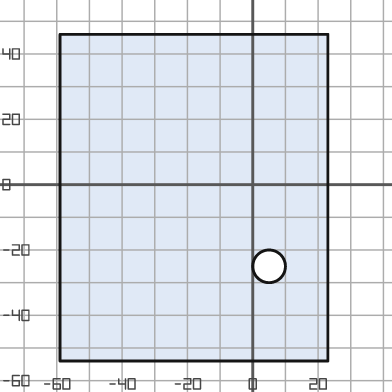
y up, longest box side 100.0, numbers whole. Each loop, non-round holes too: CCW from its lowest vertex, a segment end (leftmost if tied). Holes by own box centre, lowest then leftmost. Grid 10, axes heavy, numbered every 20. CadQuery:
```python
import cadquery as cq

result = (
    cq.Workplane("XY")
    .moveTo(-59.0, -54.0)
    .lineTo(23.0, -54.0)
    .lineTo(23.0, 46.0)
    .lineTo(-59.0, 46.0)
    .close()
    .moveTo(5.0, -25.0)
    .circle(5.0)
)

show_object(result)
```